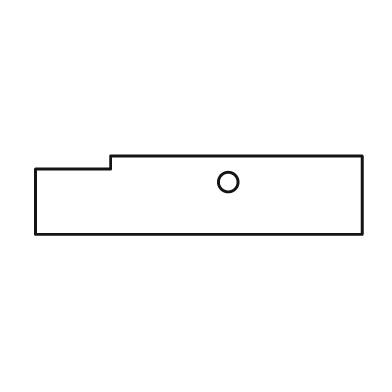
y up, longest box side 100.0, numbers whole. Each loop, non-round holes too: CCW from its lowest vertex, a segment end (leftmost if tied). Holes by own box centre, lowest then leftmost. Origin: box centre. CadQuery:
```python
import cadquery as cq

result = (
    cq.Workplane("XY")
    .moveTo(-50.0, -12.0)
    .lineTo(50.0, -12.0)
    .lineTo(50.0, 12.0)
    .lineTo(-27.0, 12.0)
    .lineTo(-27.0, 8.0)
    .lineTo(-50.0, 8.0)
    .close()
    .moveTo(9.0, 4.0)
    .circle(3.0)
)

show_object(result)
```